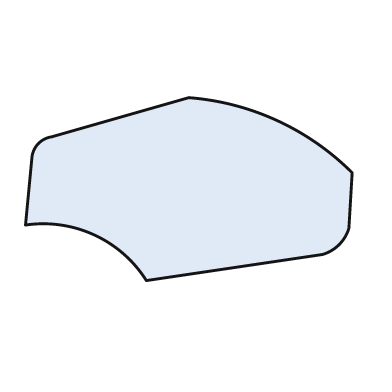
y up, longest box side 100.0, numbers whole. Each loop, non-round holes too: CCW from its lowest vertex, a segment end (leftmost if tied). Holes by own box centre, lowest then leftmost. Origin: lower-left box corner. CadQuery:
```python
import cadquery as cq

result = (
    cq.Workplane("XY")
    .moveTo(37.0, 0.0)
    .lineTo(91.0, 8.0)
    .threePointArc((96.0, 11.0), (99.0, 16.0))
    .lineTo(100.0, 33.0)
    .threePointArc((77.0, 49.0), (50.0, 56.0))
    .lineTo(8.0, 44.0)
    .threePointArc((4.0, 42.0), (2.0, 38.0))
    .lineTo(0.0, 17.0)
    .threePointArc((21.0, 14.0), (37.0, 0.0))
    .close()
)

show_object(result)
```